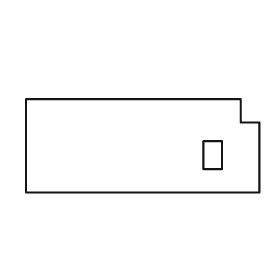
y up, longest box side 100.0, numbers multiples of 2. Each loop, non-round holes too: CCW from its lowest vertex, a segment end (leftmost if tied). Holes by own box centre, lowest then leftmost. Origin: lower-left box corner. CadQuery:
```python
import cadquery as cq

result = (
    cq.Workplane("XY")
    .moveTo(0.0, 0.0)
    .lineTo(100.0, 0.0)
    .lineTo(100.0, 30.0)
    .lineTo(92.0, 30.0)
    .lineTo(92.0, 40.0)
    .lineTo(0.0, 40.0)
    .close()
    .moveTo(76.0, 10.0)
    .lineTo(84.0, 10.0)
    .lineTo(84.0, 22.0)
    .lineTo(76.0, 22.0)
    .close()
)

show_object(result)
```